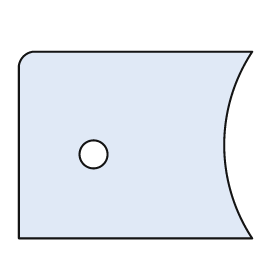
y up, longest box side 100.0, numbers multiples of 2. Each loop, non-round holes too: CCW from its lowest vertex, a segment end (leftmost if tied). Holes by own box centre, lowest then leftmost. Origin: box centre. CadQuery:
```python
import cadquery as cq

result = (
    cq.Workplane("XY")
    .moveTo(-50.0, -40.0)
    .lineTo(50.0, -40.0)
    .threePointArc((38.0, 0.0), (50.0, 40.0))
    .lineTo(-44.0, 40.0)
    .threePointArc((-48.0, 38.0), (-50.0, 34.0))
    .close()
    .moveTo(-18.0, -4.0)
    .circle(6.0)
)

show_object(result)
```